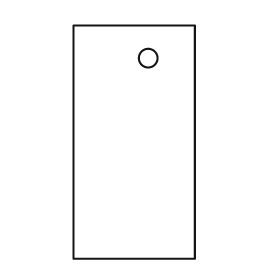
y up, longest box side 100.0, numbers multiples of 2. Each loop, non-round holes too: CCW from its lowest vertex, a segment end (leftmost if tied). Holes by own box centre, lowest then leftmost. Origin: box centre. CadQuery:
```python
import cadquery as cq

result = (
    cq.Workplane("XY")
    .moveTo(-26.0, -50.0)
    .lineTo(26.0, -50.0)
    .lineTo(26.0, 50.0)
    .lineTo(-26.0, 50.0)
    .close()
    .moveTo(6.0, 36.0)
    .circle(4.0)
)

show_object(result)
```